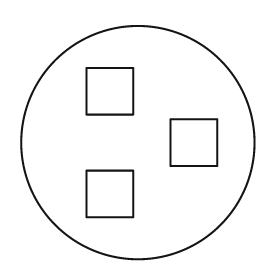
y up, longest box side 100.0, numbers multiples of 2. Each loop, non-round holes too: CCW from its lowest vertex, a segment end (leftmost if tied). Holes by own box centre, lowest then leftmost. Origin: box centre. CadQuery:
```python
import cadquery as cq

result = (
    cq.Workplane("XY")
    .moveTo(0.0, 0.0)
    .circle(50.0)
    .moveTo(-22.0, -32.0)
    .lineTo(-2.0, -32.0)
    .lineTo(-2.0, -12.0)
    .lineTo(-22.0, -12.0)
    .close()
    .moveTo(14.0, -10.0)
    .lineTo(34.0, -10.0)
    .lineTo(34.0, 10.0)
    .lineTo(14.0, 10.0)
    .close()
    .moveTo(-22.0, 12.0)
    .lineTo(-2.0, 12.0)
    .lineTo(-2.0, 32.0)
    .lineTo(-22.0, 32.0)
    .close()
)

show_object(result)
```